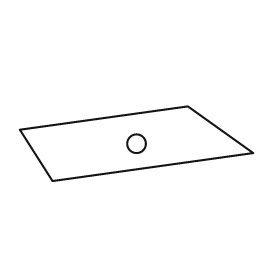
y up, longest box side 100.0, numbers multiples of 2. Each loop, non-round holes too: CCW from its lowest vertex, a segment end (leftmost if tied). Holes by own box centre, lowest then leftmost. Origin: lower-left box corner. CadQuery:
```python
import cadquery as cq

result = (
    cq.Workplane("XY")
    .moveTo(14.0, 0.0)
    .lineTo(100.0, 12.0)
    .lineTo(72.0, 32.0)
    .lineTo(0.0, 22.0)
    .close()
    .moveTo(50.0, 16.0)
    .circle(4.0)
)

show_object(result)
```